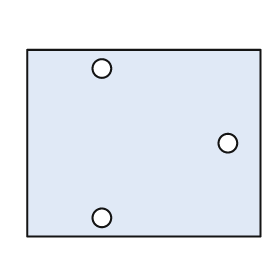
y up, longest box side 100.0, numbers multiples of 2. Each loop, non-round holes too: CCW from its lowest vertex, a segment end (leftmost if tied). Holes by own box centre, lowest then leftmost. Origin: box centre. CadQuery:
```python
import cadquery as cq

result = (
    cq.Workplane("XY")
    .moveTo(-50.0, -40.0)
    .lineTo(50.0, -40.0)
    .lineTo(50.0, 40.0)
    .lineTo(-50.0, 40.0)
    .close()
    .moveTo(-18.0, -32.0)
    .circle(4.0)
    .moveTo(36.0, 0.0)
    .circle(4.0)
    .moveTo(-18.0, 32.0)
    .circle(4.0)
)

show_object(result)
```